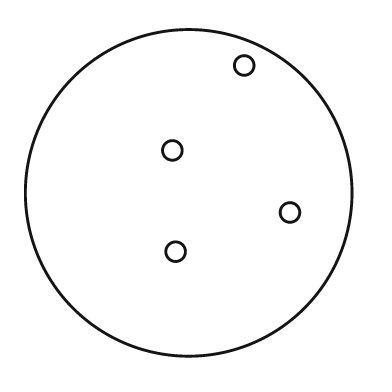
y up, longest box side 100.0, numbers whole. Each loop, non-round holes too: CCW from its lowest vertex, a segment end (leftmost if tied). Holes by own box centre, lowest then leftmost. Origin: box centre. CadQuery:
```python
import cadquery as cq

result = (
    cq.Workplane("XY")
    .moveTo(0.0, 0.0)
    .circle(50.0)
    .moveTo(-4.0, -18.0)
    .circle(3.0)
    .moveTo(31.0, -6.0)
    .circle(3.0)
    .moveTo(-5.0, 13.0)
    .circle(3.0)
    .moveTo(17.0, 39.0)
    .circle(3.0)
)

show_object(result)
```